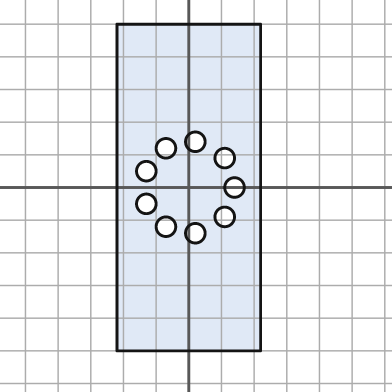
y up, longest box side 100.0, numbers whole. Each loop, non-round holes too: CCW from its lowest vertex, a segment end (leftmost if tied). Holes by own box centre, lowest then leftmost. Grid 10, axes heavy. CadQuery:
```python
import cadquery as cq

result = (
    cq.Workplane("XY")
    .moveTo(-22.0, -50.0)
    .lineTo(22.0, -50.0)
    .lineTo(22.0, 50.0)
    .lineTo(-22.0, 50.0)
    .close()
    .moveTo(2.0, -14.0)
    .circle(3.0)
    .moveTo(-7.0, -12.0)
    .circle(3.0)
    .moveTo(11.0, -9.0)
    .circle(3.0)
    .moveTo(-13.0, -5.0)
    .circle(3.0)
    .moveTo(14.0, 0.0)
    .circle(3.0)
    .moveTo(-13.0, 5.0)
    .circle(3.0)
    .moveTo(11.0, 9.0)
    .circle(3.0)
    .moveTo(-7.0, 12.0)
    .circle(3.0)
    .moveTo(2.0, 14.0)
    .circle(3.0)
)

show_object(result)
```